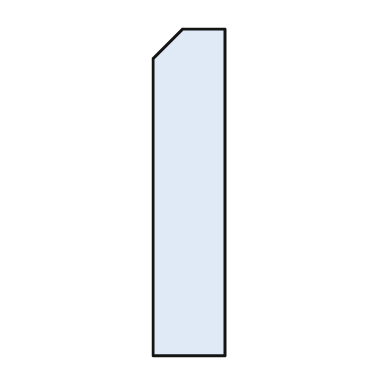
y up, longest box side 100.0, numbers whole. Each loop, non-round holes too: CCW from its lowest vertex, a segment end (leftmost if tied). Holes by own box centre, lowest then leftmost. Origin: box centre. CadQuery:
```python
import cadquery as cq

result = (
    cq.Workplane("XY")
    .moveTo(-11.0, -50.0)
    .lineTo(11.0, -50.0)
    .lineTo(11.0, 50.0)
    .lineTo(-2.0, 50.0)
    .lineTo(-11.0, 41.0)
    .close()
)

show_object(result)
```